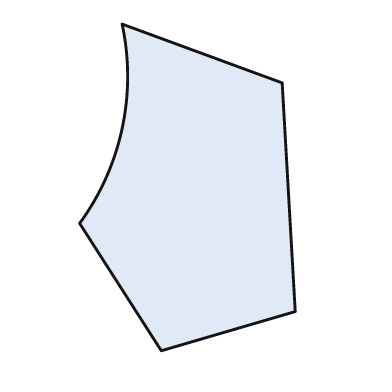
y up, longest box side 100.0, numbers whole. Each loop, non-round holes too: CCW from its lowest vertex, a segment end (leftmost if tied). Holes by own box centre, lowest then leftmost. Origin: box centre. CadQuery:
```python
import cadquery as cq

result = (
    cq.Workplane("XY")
    .moveTo(-8.0, -50.0)
    .lineTo(33.0, -38.0)
    .lineTo(29.0, 32.0)
    .lineTo(-20.0, 50.0)
    .threePointArc((-20.0, 18.0), (-33.0, -11.0))
    .close()
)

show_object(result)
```